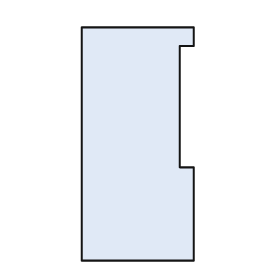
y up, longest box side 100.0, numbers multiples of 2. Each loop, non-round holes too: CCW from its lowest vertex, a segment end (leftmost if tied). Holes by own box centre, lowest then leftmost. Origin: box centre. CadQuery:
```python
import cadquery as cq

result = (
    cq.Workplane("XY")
    .moveTo(-24.0, -50.0)
    .lineTo(24.0, -50.0)
    .lineTo(24.0, -10.0)
    .lineTo(18.0, -10.0)
    .lineTo(18.0, 42.0)
    .lineTo(24.0, 42.0)
    .lineTo(24.0, 50.0)
    .lineTo(-24.0, 50.0)
    .close()
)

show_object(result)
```